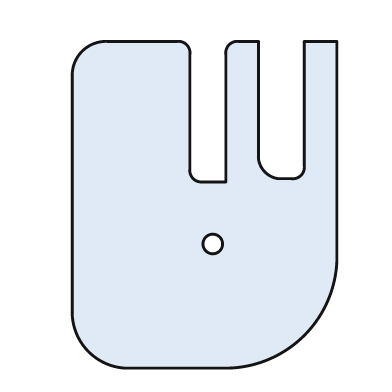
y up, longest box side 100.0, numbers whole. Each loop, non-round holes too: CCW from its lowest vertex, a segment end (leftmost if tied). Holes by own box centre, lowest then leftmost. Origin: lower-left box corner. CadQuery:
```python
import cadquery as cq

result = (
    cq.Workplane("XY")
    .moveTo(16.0, 0.0)
    .lineTo(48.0, 0.0)
    .threePointArc((71.0, 10.0), (81.0, 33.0))
    .lineTo(81.0, 100.0)
    .lineTo(71.0, 100.0)
    .lineTo(71.0, 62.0)
    .threePointArc((70.0, 59.0), (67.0, 58.0))
    .lineTo(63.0, 58.0)
    .threePointArc((59.0, 60.0), (57.0, 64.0))
    .lineTo(57.0, 100.0)
    .lineTo(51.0, 100.0)
    .threePointArc((48.0, 99.0), (47.0, 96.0))
    .lineTo(47.0, 57.0)
    .lineTo(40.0, 57.0)
    .threePointArc((37.0, 58.0), (36.0, 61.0))
    .lineTo(36.0, 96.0)
    .threePointArc((35.0, 99.0), (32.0, 100.0))
    .lineTo(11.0, 100.0)
    .threePointArc((3.0, 97.0), (0.0, 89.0))
    .lineTo(0.0, 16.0)
    .threePointArc((5.0, 5.0), (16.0, 0.0))
    .close()
    .moveTo(43.0, 38.0)
    .circle(3.0)
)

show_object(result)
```